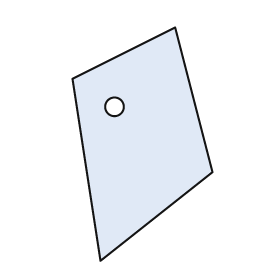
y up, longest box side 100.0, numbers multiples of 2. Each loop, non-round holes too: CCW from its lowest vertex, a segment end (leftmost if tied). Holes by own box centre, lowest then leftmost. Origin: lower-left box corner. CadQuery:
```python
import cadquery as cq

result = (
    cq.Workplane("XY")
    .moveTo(12.0, 0.0)
    .lineTo(60.0, 38.0)
    .lineTo(44.0, 100.0)
    .lineTo(0.0, 78.0)
    .close()
    .moveTo(18.0, 66.0)
    .circle(4.0)
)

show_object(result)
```